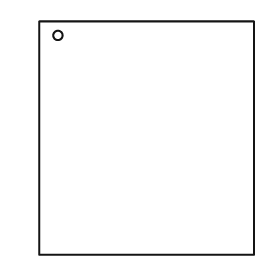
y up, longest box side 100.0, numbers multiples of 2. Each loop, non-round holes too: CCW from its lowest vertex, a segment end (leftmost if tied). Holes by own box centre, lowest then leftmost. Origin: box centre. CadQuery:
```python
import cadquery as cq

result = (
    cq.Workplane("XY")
    .moveTo(-46.0, -50.0)
    .lineTo(46.0, -50.0)
    .lineTo(46.0, 50.0)
    .lineTo(-46.0, 50.0)
    .close()
    .moveTo(-38.0, 44.0)
    .circle(2.0)
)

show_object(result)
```